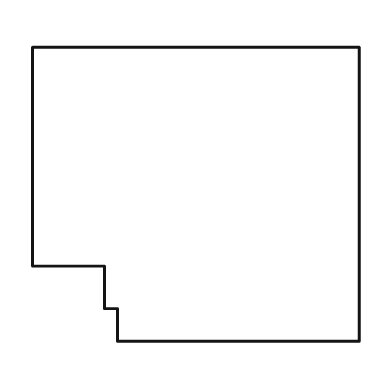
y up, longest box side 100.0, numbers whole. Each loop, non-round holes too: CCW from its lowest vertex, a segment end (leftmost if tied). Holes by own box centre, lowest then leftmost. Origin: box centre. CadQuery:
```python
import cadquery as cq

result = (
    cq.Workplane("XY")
    .moveTo(-24.0, -45.0)
    .lineTo(50.0, -45.0)
    .lineTo(50.0, 45.0)
    .lineTo(-50.0, 45.0)
    .lineTo(-50.0, -22.0)
    .lineTo(-28.0, -22.0)
    .lineTo(-28.0, -35.0)
    .lineTo(-24.0, -35.0)
    .close()
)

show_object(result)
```